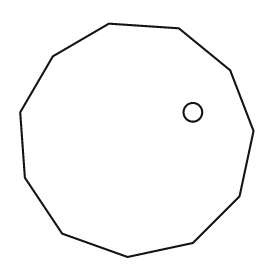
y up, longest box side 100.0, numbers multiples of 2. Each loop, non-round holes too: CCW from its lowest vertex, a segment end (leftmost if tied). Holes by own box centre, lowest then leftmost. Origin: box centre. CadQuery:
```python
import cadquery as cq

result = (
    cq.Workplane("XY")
    .moveTo(-4.0, -50.0)
    .lineTo(24.0, -44.0)
    .lineTo(44.0, -24.0)
    .lineTo(50.0, 4.0)
    .lineTo(40.0, 30.0)
    .lineTo(18.0, 48.0)
    .lineTo(-12.0, 50.0)
    .lineTo(-36.0, 36.0)
    .lineTo(-50.0, 12.0)
    .lineTo(-48.0, -16.0)
    .lineTo(-32.0, -40.0)
    .close()
    .moveTo(24.0, 12.0)
    .circle(4.0)
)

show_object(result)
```